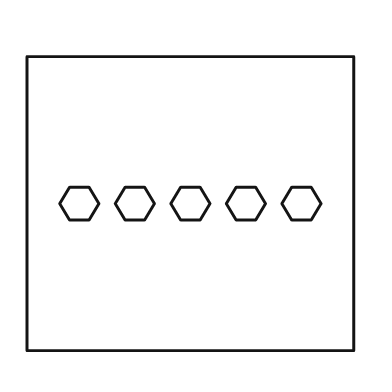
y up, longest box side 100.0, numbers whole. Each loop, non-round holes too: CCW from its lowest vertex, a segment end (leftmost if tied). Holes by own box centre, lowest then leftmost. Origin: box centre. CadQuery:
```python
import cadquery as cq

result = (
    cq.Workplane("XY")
    .moveTo(-50.0, -45.0)
    .lineTo(50.0, -45.0)
    .lineTo(50.0, 45.0)
    .lineTo(-50.0, 45.0)
    .close()
    .moveTo(-37.0, -5.0)
    .lineTo(-31.0, -5.0)
    .lineTo(-28.0, 0.0)
    .lineTo(-31.0, 5.0)
    .lineTo(-37.0, 5.0)
    .lineTo(-40.0, 0.0)
    .close()
    .moveTo(-20.0, -5.0)
    .lineTo(-14.0, -5.0)
    .lineTo(-11.0, 0.0)
    .lineTo(-14.0, 5.0)
    .lineTo(-20.0, 5.0)
    .lineTo(-23.0, 0.0)
    .close()
    .moveTo(-3.0, -5.0)
    .lineTo(3.0, -5.0)
    .lineTo(6.0, 0.0)
    .lineTo(3.0, 5.0)
    .lineTo(-3.0, 5.0)
    .lineTo(-6.0, 0.0)
    .close()
    .moveTo(14.0, -5.0)
    .lineTo(20.0, -5.0)
    .lineTo(23.0, 0.0)
    .lineTo(20.0, 5.0)
    .lineTo(14.0, 5.0)
    .lineTo(11.0, 0.0)
    .close()
    .moveTo(31.0, -5.0)
    .lineTo(37.0, -5.0)
    .lineTo(40.0, 0.0)
    .lineTo(37.0, 5.0)
    .lineTo(31.0, 5.0)
    .lineTo(28.0, 0.0)
    .close()
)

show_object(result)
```